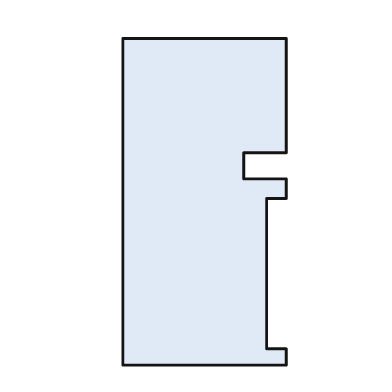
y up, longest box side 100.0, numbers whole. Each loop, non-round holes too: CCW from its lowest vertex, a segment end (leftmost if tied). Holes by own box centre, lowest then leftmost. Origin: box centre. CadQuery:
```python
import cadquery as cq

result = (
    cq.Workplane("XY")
    .moveTo(-25.0, -50.0)
    .lineTo(25.0, -50.0)
    .lineTo(25.0, -45.0)
    .lineTo(19.0, -45.0)
    .lineTo(19.0, 1.0)
    .lineTo(25.0, 1.0)
    .lineTo(25.0, 7.0)
    .lineTo(12.0, 7.0)
    .lineTo(12.0, 15.0)
    .lineTo(25.0, 15.0)
    .lineTo(25.0, 50.0)
    .lineTo(-25.0, 50.0)
    .close()
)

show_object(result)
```